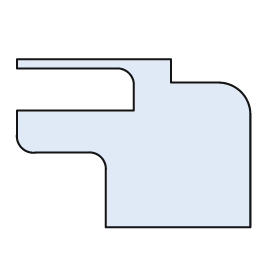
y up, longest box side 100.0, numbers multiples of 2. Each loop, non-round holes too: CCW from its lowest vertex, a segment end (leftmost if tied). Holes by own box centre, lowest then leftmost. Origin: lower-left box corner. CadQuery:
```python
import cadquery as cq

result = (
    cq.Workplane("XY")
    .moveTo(38.0, 0.0)
    .lineTo(100.0, 0.0)
    .lineTo(100.0, 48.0)
    .threePointArc((96.0, 58.0), (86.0, 62.0))
    .lineTo(66.0, 62.0)
    .lineTo(66.0, 72.0)
    .lineTo(0.0, 72.0)
    .lineTo(0.0, 68.0)
    .lineTo(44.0, 68.0)
    .threePointArc((48.0, 66.0), (50.0, 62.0))
    .lineTo(50.0, 50.0)
    .lineTo(0.0, 50.0)
    .lineTo(0.0, 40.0)
    .threePointArc((2.0, 34.0), (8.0, 32.0))
    .lineTo(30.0, 32.0)
    .threePointArc((36.0, 30.0), (38.0, 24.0))
    .close()
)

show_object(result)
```